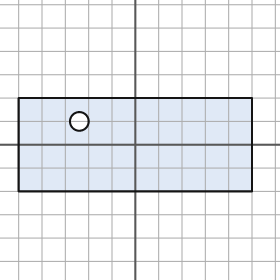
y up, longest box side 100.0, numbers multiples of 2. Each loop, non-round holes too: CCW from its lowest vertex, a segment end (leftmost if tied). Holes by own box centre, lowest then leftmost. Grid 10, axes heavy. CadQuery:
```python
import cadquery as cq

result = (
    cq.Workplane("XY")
    .moveTo(-50.0, -20.0)
    .lineTo(50.0, -20.0)
    .lineTo(50.0, 20.0)
    .lineTo(-50.0, 20.0)
    .close()
    .moveTo(-24.0, 10.0)
    .circle(4.0)
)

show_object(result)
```